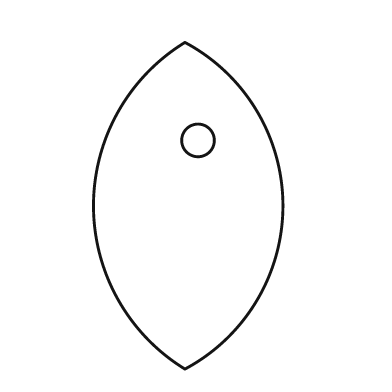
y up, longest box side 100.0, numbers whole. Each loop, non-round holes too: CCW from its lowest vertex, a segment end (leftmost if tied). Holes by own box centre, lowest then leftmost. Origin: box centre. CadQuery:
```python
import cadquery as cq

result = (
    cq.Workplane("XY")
    .moveTo(-1.0, -50.0)
    .threePointArc((29.0, 0.0), (-1.0, 50.0))
    .threePointArc((-29.0, 0.0), (-1.0, -50.0))
    .close()
    .moveTo(3.0, 20.0)
    .circle(5.0)
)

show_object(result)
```